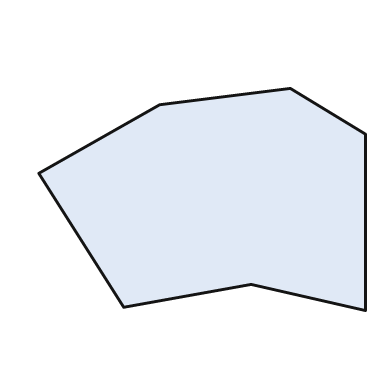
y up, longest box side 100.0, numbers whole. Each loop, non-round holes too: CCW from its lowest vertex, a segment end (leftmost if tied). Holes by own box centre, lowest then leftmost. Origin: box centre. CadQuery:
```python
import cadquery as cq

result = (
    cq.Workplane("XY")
    .moveTo(50.0, -34.0)
    .lineTo(50.0, 20.0)
    .lineTo(27.0, 34.0)
    .lineTo(-13.0, 29.0)
    .lineTo(-50.0, 8.0)
    .lineTo(-24.0, -33.0)
    .lineTo(15.0, -26.0)
    .close()
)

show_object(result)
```